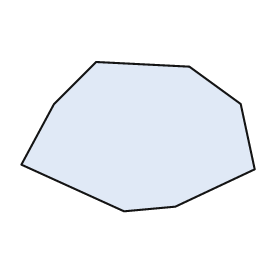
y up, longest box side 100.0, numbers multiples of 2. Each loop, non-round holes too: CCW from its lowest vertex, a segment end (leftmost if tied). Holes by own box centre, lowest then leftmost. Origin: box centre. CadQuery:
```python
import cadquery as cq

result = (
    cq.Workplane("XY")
    .moveTo(-6.0, -32.0)
    .lineTo(16.0, -30.0)
    .lineTo(50.0, -14.0)
    .lineTo(44.0, 14.0)
    .lineTo(22.0, 30.0)
    .lineTo(-18.0, 32.0)
    .lineTo(-36.0, 14.0)
    .lineTo(-50.0, -12.0)
    .close()
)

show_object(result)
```